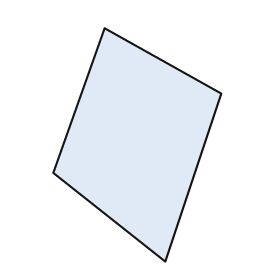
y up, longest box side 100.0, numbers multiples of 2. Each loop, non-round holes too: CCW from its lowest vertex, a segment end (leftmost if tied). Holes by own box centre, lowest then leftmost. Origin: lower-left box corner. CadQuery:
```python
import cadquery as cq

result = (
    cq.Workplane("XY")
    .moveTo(48.0, 0.0)
    .lineTo(72.0, 72.0)
    .lineTo(22.0, 100.0)
    .lineTo(0.0, 38.0)
    .close()
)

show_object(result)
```